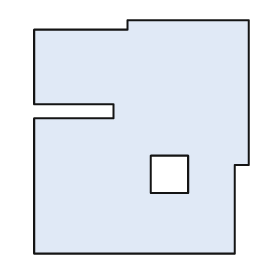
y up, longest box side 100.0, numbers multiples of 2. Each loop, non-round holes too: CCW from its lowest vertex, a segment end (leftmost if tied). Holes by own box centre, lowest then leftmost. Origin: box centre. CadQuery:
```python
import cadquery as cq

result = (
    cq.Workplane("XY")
    .moveTo(-46.0, -50.0)
    .lineTo(40.0, -50.0)
    .lineTo(40.0, -12.0)
    .lineTo(46.0, -12.0)
    .lineTo(46.0, 50.0)
    .lineTo(-6.0, 50.0)
    .lineTo(-6.0, 46.0)
    .lineTo(-46.0, 46.0)
    .lineTo(-46.0, 14.0)
    .lineTo(-12.0, 14.0)
    .lineTo(-12.0, 8.0)
    .lineTo(-46.0, 8.0)
    .close()
    .moveTo(4.0, -24.0)
    .lineTo(20.0, -24.0)
    .lineTo(20.0, -8.0)
    .lineTo(4.0, -8.0)
    .close()
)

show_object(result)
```